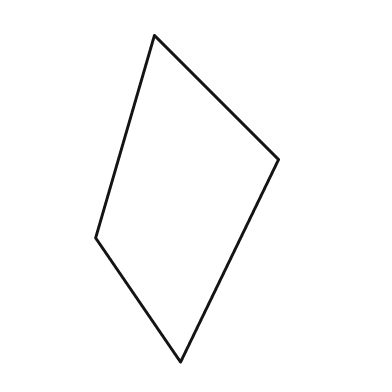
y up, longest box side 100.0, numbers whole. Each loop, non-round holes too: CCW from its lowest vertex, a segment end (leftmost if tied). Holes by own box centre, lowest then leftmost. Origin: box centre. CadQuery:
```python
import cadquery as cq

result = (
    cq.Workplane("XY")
    .moveTo(-2.0, -50.0)
    .lineTo(28.0, 12.0)
    .lineTo(-10.0, 50.0)
    .lineTo(-28.0, -12.0)
    .close()
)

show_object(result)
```